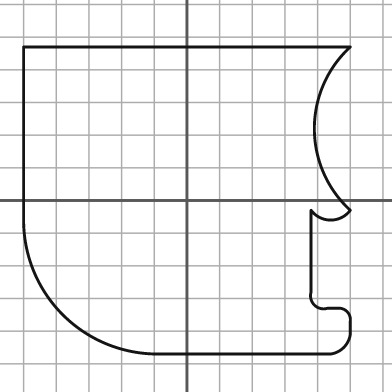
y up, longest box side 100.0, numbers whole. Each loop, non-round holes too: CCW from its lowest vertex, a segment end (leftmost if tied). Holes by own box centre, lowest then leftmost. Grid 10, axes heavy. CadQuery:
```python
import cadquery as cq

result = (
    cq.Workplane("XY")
    .moveTo(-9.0, -47.0)
    .lineTo(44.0, -47.0)
    .threePointArc((48.0, -45.0), (50.0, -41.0))
    .lineTo(50.0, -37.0)
    .threePointArc((49.0, -34.0), (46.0, -33.0))
    .lineTo(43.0, -33.0)
    .threePointArc((39.0, -32.0), (38.0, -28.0))
    .lineTo(38.0, -3.0)
    .threePointArc((44.0, -6.0), (50.0, -3.0))
    .threePointArc((39.0, 22.0), (50.0, 47.0))
    .lineTo(-50.0, 47.0)
    .lineTo(-50.0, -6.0)
    .threePointArc((-38.0, -35.0), (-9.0, -47.0))
    .close()
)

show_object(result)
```